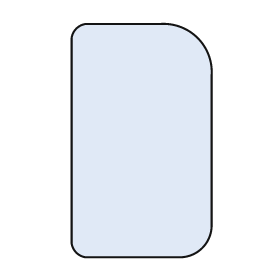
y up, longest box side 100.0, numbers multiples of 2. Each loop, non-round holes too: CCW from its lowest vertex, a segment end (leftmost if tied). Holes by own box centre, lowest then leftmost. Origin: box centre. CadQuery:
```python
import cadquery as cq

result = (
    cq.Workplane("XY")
    .moveTo(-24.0, -50.0)
    .lineTo(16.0, -50.0)
    .threePointArc((26.0, -46.0), (30.0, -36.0))
    .lineTo(30.0, 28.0)
    .threePointArc((24.0, 44.0), (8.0, 50.0))
    .lineTo(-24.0, 50.0)
    .threePointArc((-28.0, 48.0), (-30.0, 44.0))
    .lineTo(-30.0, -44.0)
    .threePointArc((-28.0, -48.0), (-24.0, -50.0))
    .close()
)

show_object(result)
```